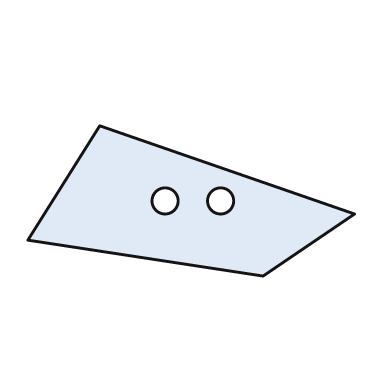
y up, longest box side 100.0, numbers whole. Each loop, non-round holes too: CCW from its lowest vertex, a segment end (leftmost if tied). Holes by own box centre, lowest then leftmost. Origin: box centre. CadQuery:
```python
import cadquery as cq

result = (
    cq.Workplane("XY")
    .moveTo(22.0, -23.0)
    .lineTo(50.0, -4.0)
    .lineTo(-28.0, 23.0)
    .lineTo(-50.0, -12.0)
    .close()
    .moveTo(-8.0, 0.0)
    .circle(4.0)
    .moveTo(9.0, 0.0)
    .circle(4.0)
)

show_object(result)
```